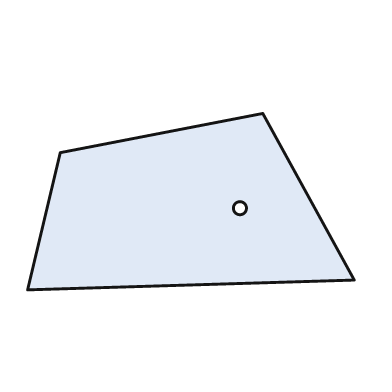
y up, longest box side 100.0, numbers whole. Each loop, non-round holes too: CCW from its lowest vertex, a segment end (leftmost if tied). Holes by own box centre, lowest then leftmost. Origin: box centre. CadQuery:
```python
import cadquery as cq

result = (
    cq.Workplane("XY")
    .moveTo(-50.0, -27.0)
    .lineTo(50.0, -24.0)
    .lineTo(22.0, 27.0)
    .lineTo(-40.0, 15.0)
    .close()
    .moveTo(15.0, -2.0)
    .circle(2.0)
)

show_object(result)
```